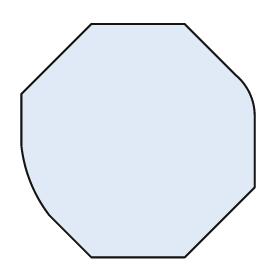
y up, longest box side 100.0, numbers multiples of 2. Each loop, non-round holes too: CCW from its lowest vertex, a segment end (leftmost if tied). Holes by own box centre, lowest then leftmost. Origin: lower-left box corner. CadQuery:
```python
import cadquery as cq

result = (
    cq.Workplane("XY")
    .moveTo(30.0, 0.0)
    .lineTo(70.0, 0.0)
    .lineTo(100.0, 30.0)
    .lineTo(100.0, 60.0)
    .threePointArc((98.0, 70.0), (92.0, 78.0))
    .lineTo(70.0, 100.0)
    .lineTo(30.0, 100.0)
    .lineTo(0.0, 70.0)
    .lineTo(0.0, 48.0)
    .threePointArc((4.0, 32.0), (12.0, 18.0))
    .close()
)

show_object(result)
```